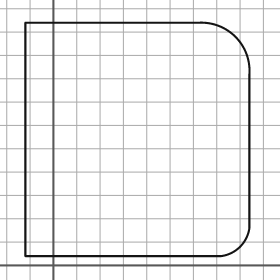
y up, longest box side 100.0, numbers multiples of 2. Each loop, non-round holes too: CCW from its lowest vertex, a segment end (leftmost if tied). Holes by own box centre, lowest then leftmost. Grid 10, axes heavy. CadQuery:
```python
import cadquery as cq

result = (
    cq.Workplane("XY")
    .moveTo(-12.0, 4.0)
    .lineTo(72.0, 4.0)
    .threePointArc((80.0, 8.0), (84.0, 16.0))
    .lineTo(84.0, 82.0)
    .threePointArc((78.0, 98.0), (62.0, 104.0))
    .lineTo(-12.0, 104.0)
    .close()
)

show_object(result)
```